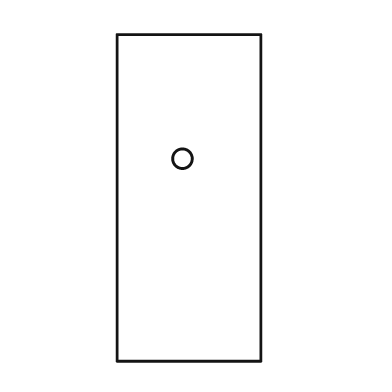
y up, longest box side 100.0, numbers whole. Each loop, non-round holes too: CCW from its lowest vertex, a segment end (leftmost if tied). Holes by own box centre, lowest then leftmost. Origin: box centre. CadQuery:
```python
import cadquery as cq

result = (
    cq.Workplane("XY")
    .moveTo(-22.0, -50.0)
    .lineTo(22.0, -50.0)
    .lineTo(22.0, 50.0)
    .lineTo(-22.0, 50.0)
    .close()
    .moveTo(-2.0, 12.0)
    .circle(3.0)
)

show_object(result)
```